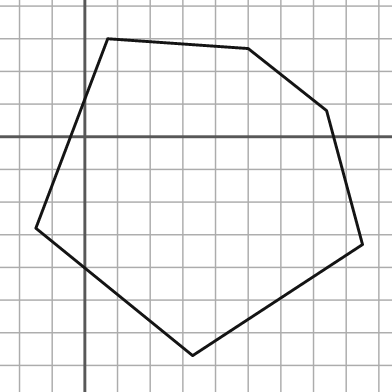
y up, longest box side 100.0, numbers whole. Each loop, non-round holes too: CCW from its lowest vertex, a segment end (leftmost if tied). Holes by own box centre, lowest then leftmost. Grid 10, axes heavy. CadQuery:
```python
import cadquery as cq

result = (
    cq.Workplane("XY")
    .moveTo(33.0, -67.0)
    .lineTo(85.0, -33.0)
    .lineTo(74.0, 8.0)
    .lineTo(50.0, 27.0)
    .lineTo(7.0, 30.0)
    .lineTo(-15.0, -28.0)
    .close()
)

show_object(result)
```